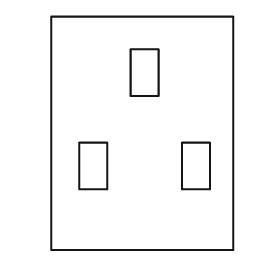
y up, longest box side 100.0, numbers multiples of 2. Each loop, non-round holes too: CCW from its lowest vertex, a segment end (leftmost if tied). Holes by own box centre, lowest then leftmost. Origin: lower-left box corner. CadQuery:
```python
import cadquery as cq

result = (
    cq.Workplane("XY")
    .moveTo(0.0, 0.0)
    .lineTo(78.0, 0.0)
    .lineTo(78.0, 100.0)
    .lineTo(0.0, 100.0)
    .close()
    .moveTo(12.0, 26.0)
    .lineTo(24.0, 26.0)
    .lineTo(24.0, 46.0)
    .lineTo(12.0, 46.0)
    .close()
    .moveTo(56.0, 26.0)
    .lineTo(68.0, 26.0)
    .lineTo(68.0, 46.0)
    .lineTo(56.0, 46.0)
    .close()
    .moveTo(34.0, 66.0)
    .lineTo(46.0, 66.0)
    .lineTo(46.0, 86.0)
    .lineTo(34.0, 86.0)
    .close()
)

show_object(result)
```